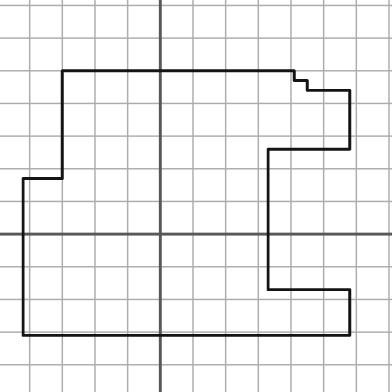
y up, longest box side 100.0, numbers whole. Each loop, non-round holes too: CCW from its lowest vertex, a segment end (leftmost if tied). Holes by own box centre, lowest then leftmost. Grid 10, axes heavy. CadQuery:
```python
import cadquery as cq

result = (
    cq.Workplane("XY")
    .moveTo(-42.0, -31.0)
    .lineTo(58.0, -31.0)
    .lineTo(58.0, -17.0)
    .lineTo(33.0, -17.0)
    .lineTo(33.0, 26.0)
    .lineTo(58.0, 26.0)
    .lineTo(58.0, 44.0)
    .lineTo(45.0, 44.0)
    .lineTo(45.0, 47.0)
    .lineTo(41.0, 47.0)
    .lineTo(41.0, 50.0)
    .lineTo(-30.0, 50.0)
    .lineTo(-30.0, 17.0)
    .lineTo(-42.0, 17.0)
    .close()
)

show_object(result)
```